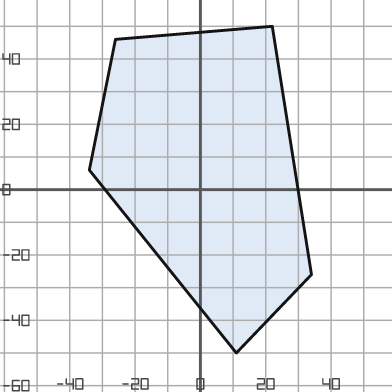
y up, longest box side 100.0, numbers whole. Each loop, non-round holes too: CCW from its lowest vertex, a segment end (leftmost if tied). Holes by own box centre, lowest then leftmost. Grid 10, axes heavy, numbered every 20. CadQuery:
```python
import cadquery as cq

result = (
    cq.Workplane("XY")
    .moveTo(11.0, -50.0)
    .lineTo(34.0, -26.0)
    .lineTo(22.0, 50.0)
    .lineTo(-26.0, 46.0)
    .lineTo(-34.0, 6.0)
    .close()
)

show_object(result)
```